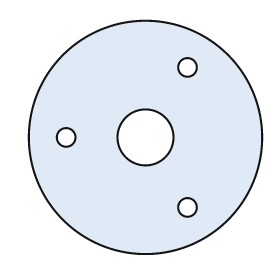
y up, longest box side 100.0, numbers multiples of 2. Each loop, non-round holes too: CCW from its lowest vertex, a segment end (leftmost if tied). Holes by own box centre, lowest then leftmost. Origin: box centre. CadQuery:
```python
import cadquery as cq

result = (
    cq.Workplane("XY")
    .moveTo(0.0, 0.0)
    .circle(50.0)
    .moveTo(18.0, -30.0)
    .circle(4.0)
    .moveTo(-34.0, 0.0)
    .circle(4.0)
    .moveTo(0.0, 0.0)
    .circle(12.0)
    .moveTo(18.0, 30.0)
    .circle(4.0)
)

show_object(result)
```